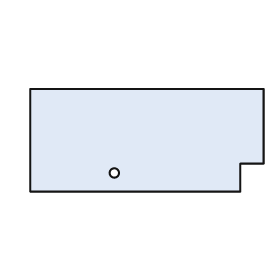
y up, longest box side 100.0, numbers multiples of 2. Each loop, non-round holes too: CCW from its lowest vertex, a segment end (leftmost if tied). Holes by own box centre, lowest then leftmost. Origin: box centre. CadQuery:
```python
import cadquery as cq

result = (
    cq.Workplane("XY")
    .moveTo(-50.0, -22.0)
    .lineTo(40.0, -22.0)
    .lineTo(40.0, -10.0)
    .lineTo(50.0, -10.0)
    .lineTo(50.0, 22.0)
    .lineTo(-50.0, 22.0)
    .close()
    .moveTo(-14.0, -14.0)
    .circle(2.0)
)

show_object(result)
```